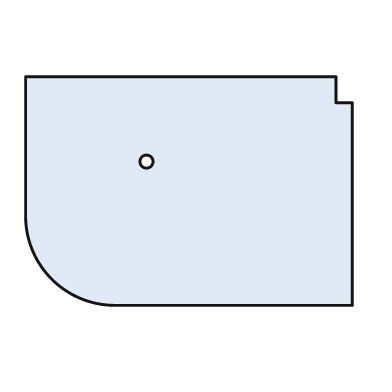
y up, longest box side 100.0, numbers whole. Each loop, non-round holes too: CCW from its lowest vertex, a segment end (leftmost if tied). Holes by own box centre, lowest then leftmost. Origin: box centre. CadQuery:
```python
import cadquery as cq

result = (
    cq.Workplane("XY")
    .moveTo(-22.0, -35.0)
    .lineTo(50.0, -35.0)
    .lineTo(50.0, 27.0)
    .lineTo(45.0, 27.0)
    .lineTo(45.0, 35.0)
    .lineTo(-50.0, 35.0)
    .lineTo(-50.0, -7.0)
    .threePointArc((-42.0, -27.0), (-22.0, -35.0))
    .close()
    .moveTo(-13.0, 9.0)
    .circle(2.0)
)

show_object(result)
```